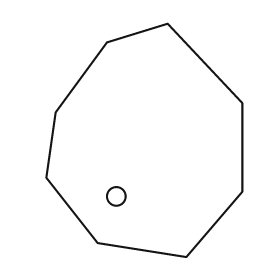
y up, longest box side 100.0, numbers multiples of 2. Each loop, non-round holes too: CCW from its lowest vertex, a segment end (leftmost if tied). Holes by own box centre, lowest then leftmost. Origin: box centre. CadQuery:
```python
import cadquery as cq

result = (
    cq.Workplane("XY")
    .moveTo(18.0, -50.0)
    .lineTo(42.0, -22.0)
    .lineTo(42.0, 16.0)
    .lineTo(10.0, 50.0)
    .lineTo(-16.0, 42.0)
    .lineTo(-38.0, 12.0)
    .lineTo(-42.0, -16.0)
    .lineTo(-20.0, -44.0)
    .close()
    .moveTo(-12.0, -24.0)
    .circle(4.0)
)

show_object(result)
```